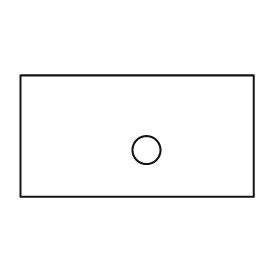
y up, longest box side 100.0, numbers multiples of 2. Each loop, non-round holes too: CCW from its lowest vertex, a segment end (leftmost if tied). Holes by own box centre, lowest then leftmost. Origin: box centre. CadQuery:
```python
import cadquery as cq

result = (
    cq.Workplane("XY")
    .moveTo(-50.0, -26.0)
    .lineTo(50.0, -26.0)
    .lineTo(50.0, 26.0)
    .lineTo(-50.0, 26.0)
    .close()
    .moveTo(4.0, -6.0)
    .circle(6.0)
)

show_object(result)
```